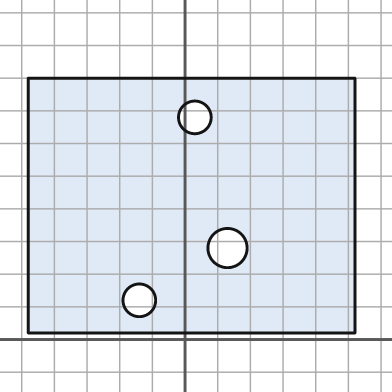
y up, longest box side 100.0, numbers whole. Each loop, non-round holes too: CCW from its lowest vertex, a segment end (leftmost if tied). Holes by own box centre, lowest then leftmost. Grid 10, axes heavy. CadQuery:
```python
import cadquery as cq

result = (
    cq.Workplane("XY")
    .moveTo(-48.0, 2.0)
    .lineTo(52.0, 2.0)
    .lineTo(52.0, 80.0)
    .lineTo(-48.0, 80.0)
    .close()
    .moveTo(-14.0, 12.0)
    .circle(5.0)
    .moveTo(13.0, 28.0)
    .circle(6.0)
    .moveTo(3.0, 68.0)
    .circle(5.0)
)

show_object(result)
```